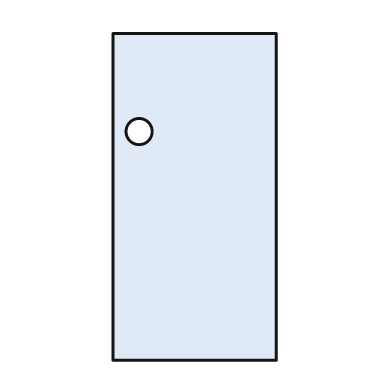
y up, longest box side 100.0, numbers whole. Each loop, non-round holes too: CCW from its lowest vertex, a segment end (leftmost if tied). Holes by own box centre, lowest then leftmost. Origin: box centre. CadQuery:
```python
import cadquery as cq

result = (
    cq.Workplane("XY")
    .moveTo(-25.0, -50.0)
    .lineTo(25.0, -50.0)
    .lineTo(25.0, 50.0)
    .lineTo(-25.0, 50.0)
    .close()
    .moveTo(-17.0, 20.0)
    .circle(4.0)
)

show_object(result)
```